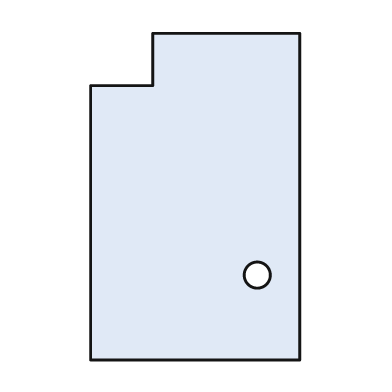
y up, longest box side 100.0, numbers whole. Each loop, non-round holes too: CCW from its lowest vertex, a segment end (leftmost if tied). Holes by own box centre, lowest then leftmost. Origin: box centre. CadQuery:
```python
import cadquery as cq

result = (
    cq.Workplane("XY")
    .moveTo(-32.0, -50.0)
    .lineTo(32.0, -50.0)
    .lineTo(32.0, 50.0)
    .lineTo(-13.0, 50.0)
    .lineTo(-13.0, 34.0)
    .lineTo(-32.0, 34.0)
    .close()
    .moveTo(19.0, -24.0)
    .circle(4.0)
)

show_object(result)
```